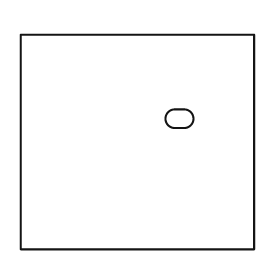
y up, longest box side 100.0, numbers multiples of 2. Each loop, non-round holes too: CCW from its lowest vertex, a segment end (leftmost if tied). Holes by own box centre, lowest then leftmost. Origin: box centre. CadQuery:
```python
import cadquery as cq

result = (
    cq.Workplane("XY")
    .moveTo(-50.0, -46.0)
    .lineTo(50.0, -46.0)
    .lineTo(50.0, 46.0)
    .lineTo(-50.0, 46.0)
    .close()
    .moveTo(16.0, 6.0)
    .lineTo(20.0, 6.0)
    .threePointArc((24.0, 10.0), (20.0, 14.0))
    .lineTo(16.0, 14.0)
    .threePointArc((12.0, 10.0), (16.0, 6.0))
    .close()
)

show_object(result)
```